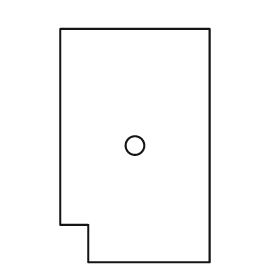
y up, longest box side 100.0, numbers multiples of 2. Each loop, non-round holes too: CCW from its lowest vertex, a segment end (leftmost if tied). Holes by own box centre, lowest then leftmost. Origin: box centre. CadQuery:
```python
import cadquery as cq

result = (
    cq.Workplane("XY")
    .moveTo(-20.0, -50.0)
    .lineTo(32.0, -50.0)
    .lineTo(32.0, 50.0)
    .lineTo(-32.0, 50.0)
    .lineTo(-32.0, -34.0)
    .lineTo(-20.0, -34.0)
    .close()
    .moveTo(0.0, 0.0)
    .circle(4.0)
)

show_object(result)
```